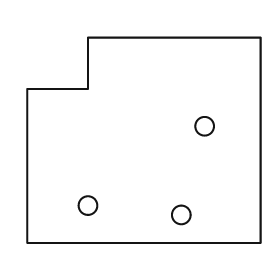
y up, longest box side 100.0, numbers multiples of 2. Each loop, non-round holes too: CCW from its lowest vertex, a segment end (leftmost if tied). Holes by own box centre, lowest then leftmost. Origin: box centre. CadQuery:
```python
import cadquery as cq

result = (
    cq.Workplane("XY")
    .moveTo(-50.0, -44.0)
    .lineTo(50.0, -44.0)
    .lineTo(50.0, 44.0)
    .lineTo(-24.0, 44.0)
    .lineTo(-24.0, 22.0)
    .lineTo(-50.0, 22.0)
    .close()
    .moveTo(16.0, -32.0)
    .circle(4.0)
    .moveTo(-24.0, -28.0)
    .circle(4.0)
    .moveTo(26.0, 6.0)
    .circle(4.0)
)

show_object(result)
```